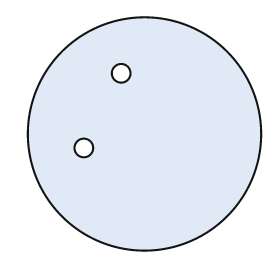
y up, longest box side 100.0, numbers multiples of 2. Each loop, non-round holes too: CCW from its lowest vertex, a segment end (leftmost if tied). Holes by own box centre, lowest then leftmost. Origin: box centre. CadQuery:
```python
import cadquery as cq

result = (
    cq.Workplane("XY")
    .moveTo(0.0, 0.0)
    .circle(50.0)
    .moveTo(-26.0, -6.0)
    .circle(4.0)
    .moveTo(-10.0, 26.0)
    .circle(4.0)
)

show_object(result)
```